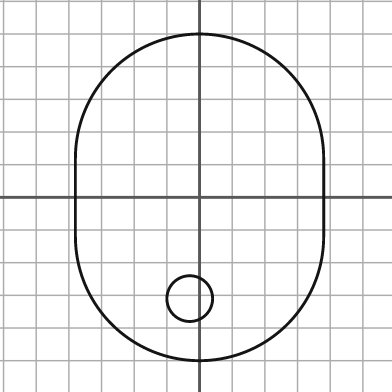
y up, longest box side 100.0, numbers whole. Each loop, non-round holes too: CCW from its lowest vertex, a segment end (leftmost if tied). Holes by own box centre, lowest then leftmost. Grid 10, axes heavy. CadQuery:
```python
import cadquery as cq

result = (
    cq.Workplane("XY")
    .moveTo(-38.0, -12.0)
    .threePointArc((0.0, -50.0), (38.0, -12.0))
    .lineTo(38.0, 12.0)
    .threePointArc((0.0, 50.0), (-38.0, 12.0))
    .close()
    .moveTo(-3.0, -31.0)
    .circle(7.0)
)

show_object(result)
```